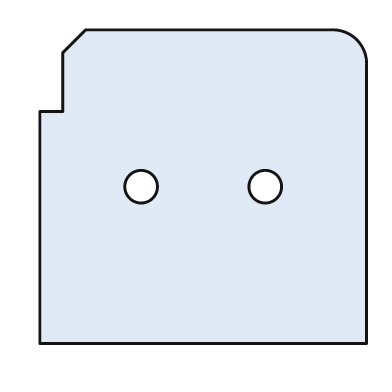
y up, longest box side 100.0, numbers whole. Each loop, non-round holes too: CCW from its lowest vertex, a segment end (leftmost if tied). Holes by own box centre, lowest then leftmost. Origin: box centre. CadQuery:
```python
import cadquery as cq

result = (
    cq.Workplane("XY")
    .moveTo(-50.0, -48.0)
    .lineTo(50.0, -48.0)
    .lineTo(50.0, 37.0)
    .threePointArc((47.0, 45.0), (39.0, 48.0))
    .lineTo(-36.0, 48.0)
    .lineTo(-43.0, 41.0)
    .lineTo(-43.0, 23.0)
    .lineTo(-50.0, 23.0)
    .close()
    .moveTo(-19.0, 0.0)
    .circle(5.0)
    .moveTo(19.0, 0.0)
    .circle(5.0)
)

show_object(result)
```